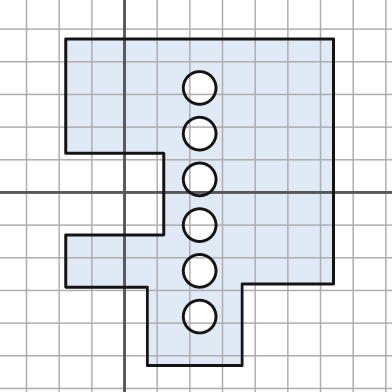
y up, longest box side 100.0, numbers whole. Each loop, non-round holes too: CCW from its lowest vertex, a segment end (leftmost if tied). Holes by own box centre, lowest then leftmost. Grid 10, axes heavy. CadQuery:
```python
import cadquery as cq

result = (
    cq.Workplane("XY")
    .moveTo(7.0, -53.0)
    .lineTo(36.0, -53.0)
    .lineTo(36.0, -28.0)
    .lineTo(64.0, -28.0)
    .lineTo(64.0, 47.0)
    .lineTo(-18.0, 47.0)
    .lineTo(-18.0, 12.0)
    .lineTo(12.0, 12.0)
    .lineTo(12.0, -13.0)
    .lineTo(-18.0, -13.0)
    .lineTo(-18.0, -29.0)
    .lineTo(7.0, -29.0)
    .close()
    .moveTo(23.0, -38.0)
    .circle(5.0)
    .moveTo(23.0, -24.0)
    .circle(5.0)
    .moveTo(23.0, -10.0)
    .circle(5.0)
    .moveTo(23.0, 4.0)
    .circle(5.0)
    .moveTo(23.0, 18.0)
    .circle(5.0)
    .moveTo(23.0, 32.0)
    .circle(5.0)
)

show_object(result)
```